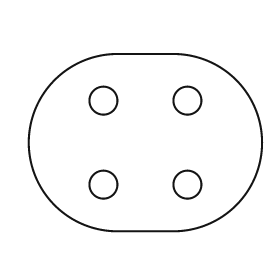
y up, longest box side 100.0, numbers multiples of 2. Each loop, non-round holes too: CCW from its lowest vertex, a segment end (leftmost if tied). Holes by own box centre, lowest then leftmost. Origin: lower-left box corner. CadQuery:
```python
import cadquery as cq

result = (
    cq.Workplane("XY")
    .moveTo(38.0, 0.0)
    .lineTo(62.0, 0.0)
    .threePointArc((100.0, 38.0), (62.0, 76.0))
    .lineTo(38.0, 76.0)
    .threePointArc((0.0, 38.0), (38.0, 0.0))
    .close()
    .moveTo(32.0, 20.0)
    .circle(6.0)
    .moveTo(68.0, 20.0)
    .circle(6.0)
    .moveTo(32.0, 56.0)
    .circle(6.0)
    .moveTo(68.0, 56.0)
    .circle(6.0)
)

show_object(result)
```